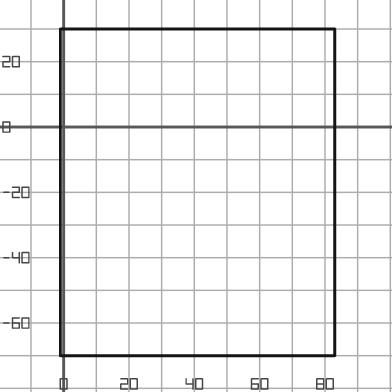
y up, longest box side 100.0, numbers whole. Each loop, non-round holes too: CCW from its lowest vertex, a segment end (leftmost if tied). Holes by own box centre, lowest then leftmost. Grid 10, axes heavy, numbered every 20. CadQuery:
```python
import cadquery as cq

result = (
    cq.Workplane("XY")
    .moveTo(-1.0, -70.0)
    .lineTo(83.0, -70.0)
    .lineTo(83.0, 30.0)
    .lineTo(-1.0, 30.0)
    .close()
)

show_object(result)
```